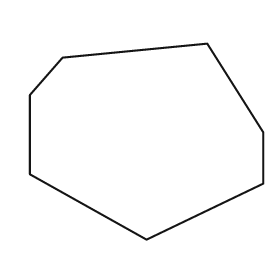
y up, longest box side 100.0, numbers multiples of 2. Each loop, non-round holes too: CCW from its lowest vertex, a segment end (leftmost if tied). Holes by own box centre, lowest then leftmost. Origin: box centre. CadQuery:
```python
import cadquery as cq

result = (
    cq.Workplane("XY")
    .moveTo(0.0, -42.0)
    .lineTo(50.0, -18.0)
    .lineTo(50.0, 4.0)
    .lineTo(26.0, 42.0)
    .lineTo(-36.0, 36.0)
    .lineTo(-50.0, 20.0)
    .lineTo(-50.0, -14.0)
    .close()
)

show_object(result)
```